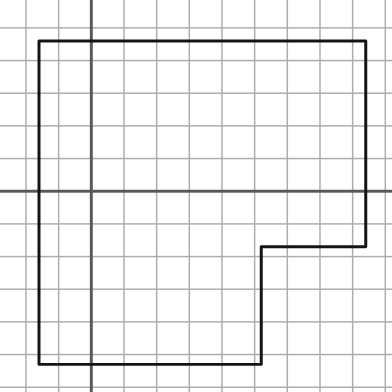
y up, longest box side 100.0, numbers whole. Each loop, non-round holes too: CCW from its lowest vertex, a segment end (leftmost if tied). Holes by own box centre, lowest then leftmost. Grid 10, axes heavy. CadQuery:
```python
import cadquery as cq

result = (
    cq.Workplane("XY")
    .moveTo(-16.0, -53.0)
    .lineTo(52.0, -53.0)
    .lineTo(52.0, -17.0)
    .lineTo(84.0, -17.0)
    .lineTo(84.0, 46.0)
    .lineTo(-16.0, 46.0)
    .close()
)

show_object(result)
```